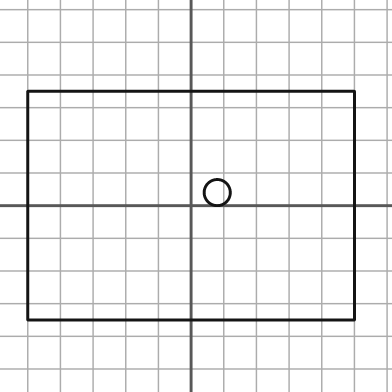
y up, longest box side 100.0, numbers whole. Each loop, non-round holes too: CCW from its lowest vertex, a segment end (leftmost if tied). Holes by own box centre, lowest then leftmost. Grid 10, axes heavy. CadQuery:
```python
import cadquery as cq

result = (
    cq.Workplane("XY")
    .moveTo(-50.0, -35.0)
    .lineTo(50.0, -35.0)
    .lineTo(50.0, 35.0)
    .lineTo(-50.0, 35.0)
    .close()
    .moveTo(8.0, 4.0)
    .circle(4.0)
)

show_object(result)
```